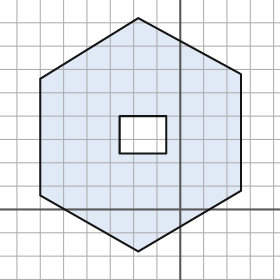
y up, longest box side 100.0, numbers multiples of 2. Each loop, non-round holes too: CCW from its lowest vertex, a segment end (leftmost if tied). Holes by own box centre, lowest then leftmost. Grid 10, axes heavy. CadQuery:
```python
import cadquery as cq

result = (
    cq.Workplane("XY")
    .moveTo(-18.0, -18.0)
    .lineTo(26.0, 8.0)
    .lineTo(26.0, 58.0)
    .lineTo(-18.0, 82.0)
    .lineTo(-60.0, 56.0)
    .lineTo(-60.0, 6.0)
    .close()
    .moveTo(-26.0, 24.0)
    .lineTo(-6.0, 24.0)
    .lineTo(-6.0, 40.0)
    .lineTo(-26.0, 40.0)
    .close()
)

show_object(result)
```